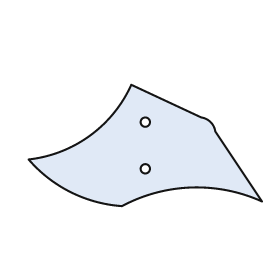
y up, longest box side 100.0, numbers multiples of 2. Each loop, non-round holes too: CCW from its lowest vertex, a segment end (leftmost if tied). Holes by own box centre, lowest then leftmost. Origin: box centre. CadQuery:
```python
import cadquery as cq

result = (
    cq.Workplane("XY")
    .moveTo(-10.0, -26.0)
    .threePointArc((20.0, -18.0), (50.0, -24.0))
    .lineTo(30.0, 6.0)
    .threePointArc((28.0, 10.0), (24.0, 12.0))
    .lineTo(-6.0, 26.0)
    .threePointArc((-24.0, 4.0), (-50.0, -6.0))
    .threePointArc((-32.0, -20.0), (-10.0, -26.0))
    .close()
    .moveTo(0.0, -10.0)
    .circle(2.0)
    .moveTo(0.0, 10.0)
    .circle(2.0)
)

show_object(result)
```